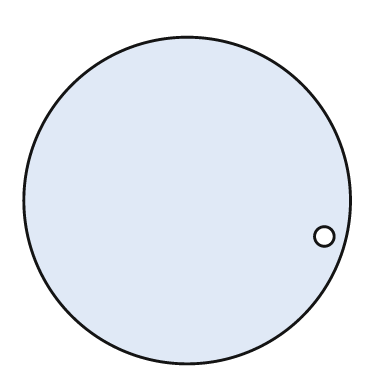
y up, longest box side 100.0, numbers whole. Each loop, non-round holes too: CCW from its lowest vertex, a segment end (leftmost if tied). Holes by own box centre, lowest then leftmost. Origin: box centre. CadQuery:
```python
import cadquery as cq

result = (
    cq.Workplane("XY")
    .moveTo(0.0, 0.0)
    .circle(50.0)
    .moveTo(42.0, -11.0)
    .circle(3.0)
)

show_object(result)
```